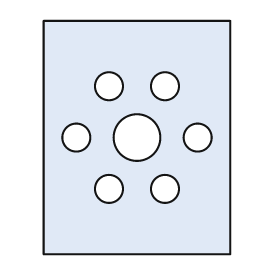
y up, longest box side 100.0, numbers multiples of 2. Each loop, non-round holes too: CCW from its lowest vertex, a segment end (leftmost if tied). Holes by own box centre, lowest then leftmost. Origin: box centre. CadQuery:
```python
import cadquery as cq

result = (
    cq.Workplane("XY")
    .moveTo(-40.0, -50.0)
    .lineTo(40.0, -50.0)
    .lineTo(40.0, 50.0)
    .lineTo(-40.0, 50.0)
    .close()
    .moveTo(-12.0, -22.0)
    .circle(6.0)
    .moveTo(12.0, -22.0)
    .circle(6.0)
    .moveTo(-26.0, 0.0)
    .circle(6.0)
    .moveTo(0.0, 0.0)
    .circle(10.0)
    .moveTo(26.0, 0.0)
    .circle(6.0)
    .moveTo(-12.0, 22.0)
    .circle(6.0)
    .moveTo(12.0, 22.0)
    .circle(6.0)
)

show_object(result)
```